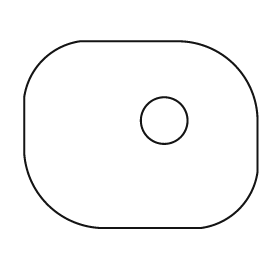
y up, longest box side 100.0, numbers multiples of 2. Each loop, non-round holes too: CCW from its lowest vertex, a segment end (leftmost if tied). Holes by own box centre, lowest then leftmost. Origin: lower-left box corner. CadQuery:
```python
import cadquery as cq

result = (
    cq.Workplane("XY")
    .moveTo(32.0, 0.0)
    .lineTo(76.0, 0.0)
    .threePointArc((92.0, 8.0), (100.0, 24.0))
    .lineTo(100.0, 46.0)
    .threePointArc((90.0, 70.0), (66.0, 80.0))
    .lineTo(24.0, 80.0)
    .threePointArc((8.0, 72.0), (0.0, 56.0))
    .lineTo(0.0, 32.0)
    .threePointArc((10.0, 10.0), (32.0, 0.0))
    .close()
    .moveTo(60.0, 46.0)
    .circle(10.0)
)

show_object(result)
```